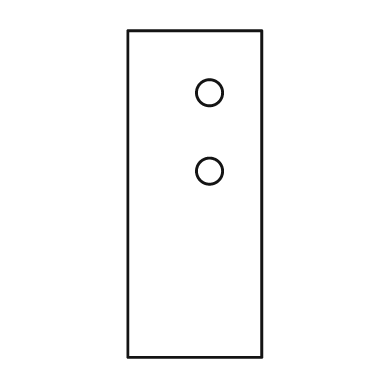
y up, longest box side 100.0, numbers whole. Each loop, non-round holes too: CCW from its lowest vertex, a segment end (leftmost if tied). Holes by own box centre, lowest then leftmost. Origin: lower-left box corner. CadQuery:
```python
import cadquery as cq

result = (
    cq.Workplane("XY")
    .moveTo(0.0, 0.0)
    .lineTo(41.0, 0.0)
    .lineTo(41.0, 100.0)
    .lineTo(0.0, 100.0)
    .close()
    .moveTo(25.0, 57.0)
    .circle(4.0)
    .moveTo(25.0, 81.0)
    .circle(4.0)
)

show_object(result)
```